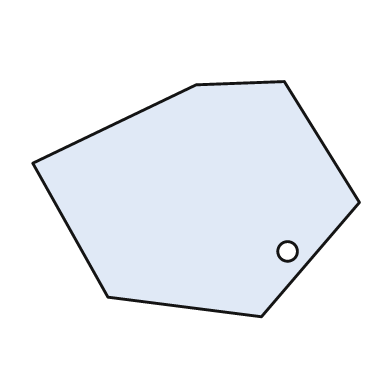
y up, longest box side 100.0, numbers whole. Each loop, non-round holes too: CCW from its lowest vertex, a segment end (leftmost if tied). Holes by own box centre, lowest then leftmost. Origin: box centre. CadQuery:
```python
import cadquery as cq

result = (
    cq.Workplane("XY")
    .moveTo(20.0, -36.0)
    .lineTo(50.0, -1.0)
    .lineTo(27.0, 36.0)
    .lineTo(0.0, 35.0)
    .lineTo(-50.0, 11.0)
    .lineTo(-27.0, -30.0)
    .close()
    .moveTo(28.0, -16.0)
    .circle(3.0)
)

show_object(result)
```